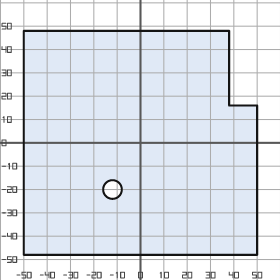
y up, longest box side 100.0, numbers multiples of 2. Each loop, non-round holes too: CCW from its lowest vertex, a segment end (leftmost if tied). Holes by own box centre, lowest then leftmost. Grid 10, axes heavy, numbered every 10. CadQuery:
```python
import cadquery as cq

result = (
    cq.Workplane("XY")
    .moveTo(-50.0, -48.0)
    .lineTo(50.0, -48.0)
    .lineTo(50.0, 16.0)
    .lineTo(38.0, 16.0)
    .lineTo(38.0, 48.0)
    .lineTo(-50.0, 48.0)
    .close()
    .moveTo(-12.0, -20.0)
    .circle(4.0)
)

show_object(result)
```